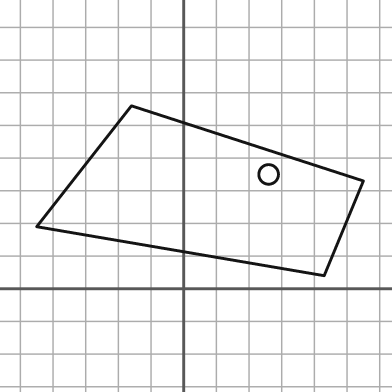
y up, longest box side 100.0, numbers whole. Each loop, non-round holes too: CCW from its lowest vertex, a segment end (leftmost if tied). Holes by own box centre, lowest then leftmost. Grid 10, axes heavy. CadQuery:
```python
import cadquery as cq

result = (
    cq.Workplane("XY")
    .moveTo(43.0, 4.0)
    .lineTo(55.0, 33.0)
    .lineTo(-16.0, 56.0)
    .lineTo(-45.0, 19.0)
    .close()
    .moveTo(26.0, 35.0)
    .circle(3.0)
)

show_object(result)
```